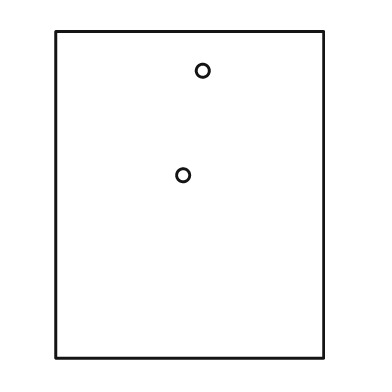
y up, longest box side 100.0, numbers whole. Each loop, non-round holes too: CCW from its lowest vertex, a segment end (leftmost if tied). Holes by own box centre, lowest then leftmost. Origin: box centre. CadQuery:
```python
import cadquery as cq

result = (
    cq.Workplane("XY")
    .moveTo(-41.0, -50.0)
    .lineTo(41.0, -50.0)
    .lineTo(41.0, 50.0)
    .lineTo(-41.0, 50.0)
    .close()
    .moveTo(-2.0, 6.0)
    .circle(2.0)
    .moveTo(4.0, 38.0)
    .circle(2.0)
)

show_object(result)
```